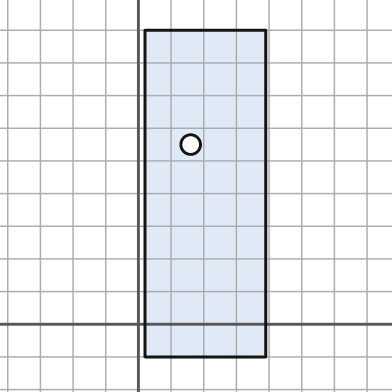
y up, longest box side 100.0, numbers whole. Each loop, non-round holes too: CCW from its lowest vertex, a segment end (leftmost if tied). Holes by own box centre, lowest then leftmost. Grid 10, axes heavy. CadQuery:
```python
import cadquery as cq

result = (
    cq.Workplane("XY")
    .moveTo(2.0, -10.0)
    .lineTo(39.0, -10.0)
    .lineTo(39.0, 90.0)
    .lineTo(2.0, 90.0)
    .close()
    .moveTo(16.0, 55.0)
    .circle(3.0)
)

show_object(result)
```